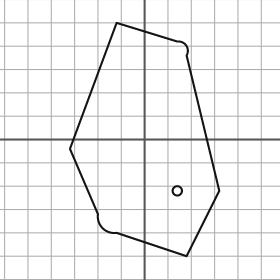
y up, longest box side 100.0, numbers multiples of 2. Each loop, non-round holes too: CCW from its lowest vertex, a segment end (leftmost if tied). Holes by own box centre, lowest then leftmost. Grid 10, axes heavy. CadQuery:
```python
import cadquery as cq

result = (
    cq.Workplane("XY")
    .moveTo(18.0, -50.0)
    .lineTo(32.0, -22.0)
    .lineTo(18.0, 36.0)
    .threePointArc((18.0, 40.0), (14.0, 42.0))
    .lineTo(-12.0, 50.0)
    .lineTo(-32.0, -4.0)
    .lineTo(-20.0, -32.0)
    .threePointArc((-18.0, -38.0), (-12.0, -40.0))
    .close()
    .moveTo(14.0, -22.0)
    .circle(2.0)
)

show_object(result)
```